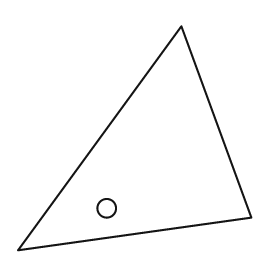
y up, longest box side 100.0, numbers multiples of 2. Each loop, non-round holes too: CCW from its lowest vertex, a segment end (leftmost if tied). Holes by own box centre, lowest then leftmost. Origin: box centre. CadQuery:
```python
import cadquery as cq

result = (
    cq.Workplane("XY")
    .moveTo(-50.0, -48.0)
    .lineTo(50.0, -34.0)
    .lineTo(20.0, 48.0)
    .close()
    .moveTo(-12.0, -30.0)
    .circle(4.0)
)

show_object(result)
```